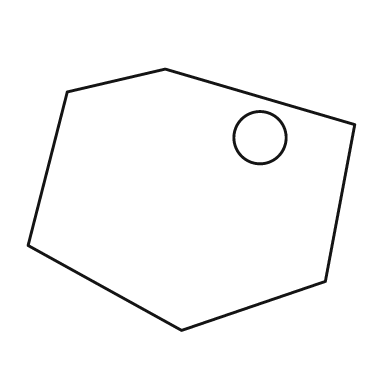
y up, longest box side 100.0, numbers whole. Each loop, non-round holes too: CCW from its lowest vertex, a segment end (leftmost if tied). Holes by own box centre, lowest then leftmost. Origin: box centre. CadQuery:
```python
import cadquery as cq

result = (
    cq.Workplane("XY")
    .moveTo(-3.0, -40.0)
    .lineTo(41.0, -25.0)
    .lineTo(50.0, 23.0)
    .lineTo(-8.0, 40.0)
    .lineTo(-38.0, 33.0)
    .lineTo(-50.0, -14.0)
    .close()
    .moveTo(21.0, 19.0)
    .circle(8.0)
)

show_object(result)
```